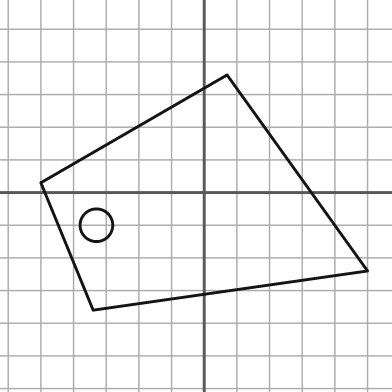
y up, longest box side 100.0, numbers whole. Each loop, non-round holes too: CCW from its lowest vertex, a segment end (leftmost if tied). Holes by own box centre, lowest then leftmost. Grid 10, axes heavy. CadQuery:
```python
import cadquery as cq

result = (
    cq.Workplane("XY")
    .moveTo(-34.0, -36.0)
    .lineTo(50.0, -24.0)
    .lineTo(7.0, 36.0)
    .lineTo(-50.0, 3.0)
    .close()
    .moveTo(-33.0, -10.0)
    .circle(5.0)
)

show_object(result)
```